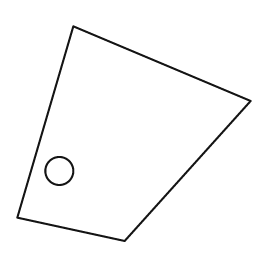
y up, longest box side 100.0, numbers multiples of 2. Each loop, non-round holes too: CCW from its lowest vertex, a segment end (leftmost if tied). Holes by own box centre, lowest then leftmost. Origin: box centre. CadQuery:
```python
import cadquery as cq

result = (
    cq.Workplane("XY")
    .moveTo(-4.0, -46.0)
    .lineTo(50.0, 14.0)
    .lineTo(-26.0, 46.0)
    .lineTo(-50.0, -36.0)
    .close()
    .moveTo(-32.0, -16.0)
    .circle(6.0)
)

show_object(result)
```